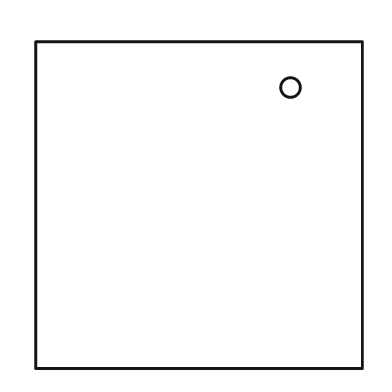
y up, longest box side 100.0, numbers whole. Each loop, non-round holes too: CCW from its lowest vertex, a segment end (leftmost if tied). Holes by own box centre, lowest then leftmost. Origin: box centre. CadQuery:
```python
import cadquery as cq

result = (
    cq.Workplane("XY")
    .moveTo(-50.0, -50.0)
    .lineTo(50.0, -50.0)
    .lineTo(50.0, 50.0)
    .lineTo(-50.0, 50.0)
    .close()
    .moveTo(28.0, 36.0)
    .circle(3.0)
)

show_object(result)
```